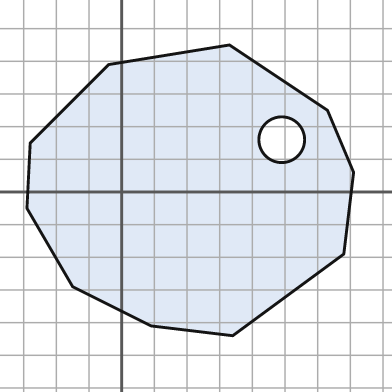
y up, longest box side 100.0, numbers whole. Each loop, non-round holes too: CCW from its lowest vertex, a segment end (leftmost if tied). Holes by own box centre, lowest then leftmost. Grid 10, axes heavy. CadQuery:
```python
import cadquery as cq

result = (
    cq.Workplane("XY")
    .moveTo(34.0, -44.0)
    .lineTo(68.0, -19.0)
    .lineTo(71.0, 6.0)
    .lineTo(63.0, 25.0)
    .lineTo(33.0, 45.0)
    .lineTo(-4.0, 39.0)
    .lineTo(-28.0, 15.0)
    .lineTo(-29.0, -5.0)
    .lineTo(-15.0, -29.0)
    .lineTo(9.0, -41.0)
    .close()
    .moveTo(49.0, 16.0)
    .circle(7.0)
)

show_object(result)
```